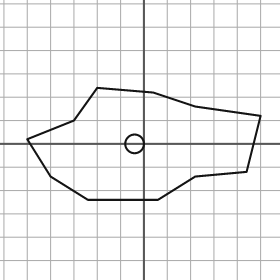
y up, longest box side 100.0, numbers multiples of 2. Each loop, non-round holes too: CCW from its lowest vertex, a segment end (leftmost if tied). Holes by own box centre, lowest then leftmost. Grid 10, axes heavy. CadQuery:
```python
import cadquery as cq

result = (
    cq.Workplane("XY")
    .moveTo(-24.0, -24.0)
    .lineTo(6.0, -24.0)
    .lineTo(22.0, -14.0)
    .lineTo(44.0, -12.0)
    .lineTo(50.0, 12.0)
    .lineTo(22.0, 16.0)
    .lineTo(4.0, 22.0)
    .lineTo(-20.0, 24.0)
    .lineTo(-30.0, 10.0)
    .lineTo(-50.0, 2.0)
    .lineTo(-40.0, -14.0)
    .close()
    .moveTo(-4.0, 0.0)
    .circle(4.0)
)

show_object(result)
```